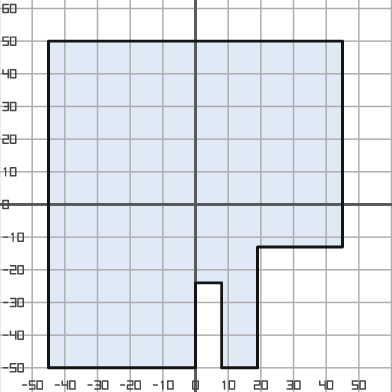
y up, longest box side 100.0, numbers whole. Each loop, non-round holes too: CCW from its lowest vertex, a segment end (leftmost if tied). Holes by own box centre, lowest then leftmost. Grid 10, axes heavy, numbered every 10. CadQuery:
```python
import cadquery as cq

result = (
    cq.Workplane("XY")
    .moveTo(-45.0, -50.0)
    .lineTo(0.0, -50.0)
    .lineTo(0.0, -24.0)
    .lineTo(8.0, -24.0)
    .lineTo(8.0, -50.0)
    .lineTo(19.0, -50.0)
    .lineTo(19.0, -13.0)
    .lineTo(45.0, -13.0)
    .lineTo(45.0, 50.0)
    .lineTo(-45.0, 50.0)
    .close()
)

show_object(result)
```